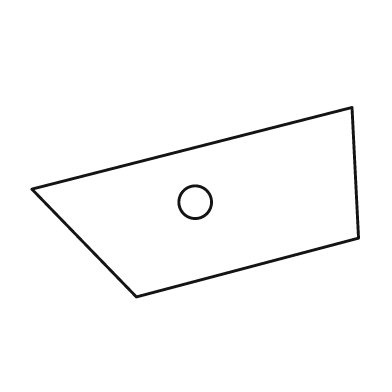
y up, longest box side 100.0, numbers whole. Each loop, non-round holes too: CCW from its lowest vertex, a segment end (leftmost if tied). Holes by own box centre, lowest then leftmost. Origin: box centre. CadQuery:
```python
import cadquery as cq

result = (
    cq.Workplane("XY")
    .moveTo(-18.0, -29.0)
    .lineTo(50.0, -11.0)
    .lineTo(48.0, 29.0)
    .lineTo(-50.0, 4.0)
    .close()
    .moveTo(0.0, 0.0)
    .circle(5.0)
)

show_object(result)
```